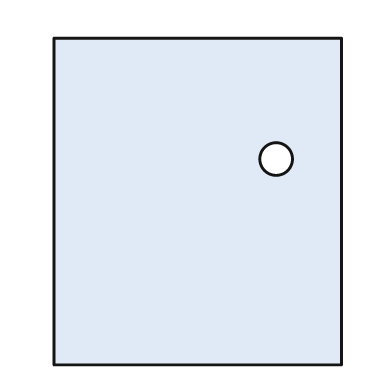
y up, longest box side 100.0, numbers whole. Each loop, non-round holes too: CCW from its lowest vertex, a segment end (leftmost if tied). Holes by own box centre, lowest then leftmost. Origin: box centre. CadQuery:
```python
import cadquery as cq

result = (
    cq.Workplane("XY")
    .moveTo(-44.0, -50.0)
    .lineTo(44.0, -50.0)
    .lineTo(44.0, 50.0)
    .lineTo(-44.0, 50.0)
    .close()
    .moveTo(24.0, 13.0)
    .circle(5.0)
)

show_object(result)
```